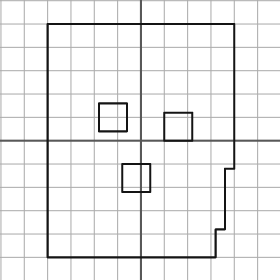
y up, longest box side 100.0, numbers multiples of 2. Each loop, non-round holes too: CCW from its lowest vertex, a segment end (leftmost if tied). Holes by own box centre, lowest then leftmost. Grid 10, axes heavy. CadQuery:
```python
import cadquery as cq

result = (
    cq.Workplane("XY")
    .moveTo(-40.0, -50.0)
    .lineTo(32.0, -50.0)
    .lineTo(32.0, -38.0)
    .lineTo(36.0, -38.0)
    .lineTo(36.0, -12.0)
    .lineTo(40.0, -12.0)
    .lineTo(40.0, 50.0)
    .lineTo(-40.0, 50.0)
    .close()
    .moveTo(-8.0, -22.0)
    .lineTo(4.0, -22.0)
    .lineTo(4.0, -10.0)
    .lineTo(-8.0, -10.0)
    .close()
    .moveTo(10.0, 0.0)
    .lineTo(22.0, 0.0)
    .lineTo(22.0, 12.0)
    .lineTo(10.0, 12.0)
    .close()
    .moveTo(-18.0, 4.0)
    .lineTo(-6.0, 4.0)
    .lineTo(-6.0, 16.0)
    .lineTo(-18.0, 16.0)
    .close()
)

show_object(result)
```